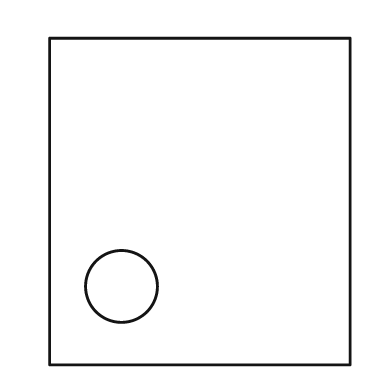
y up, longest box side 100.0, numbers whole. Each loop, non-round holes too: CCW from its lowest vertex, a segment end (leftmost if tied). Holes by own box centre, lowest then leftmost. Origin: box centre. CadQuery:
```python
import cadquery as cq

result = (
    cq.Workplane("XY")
    .moveTo(-46.0, -50.0)
    .lineTo(46.0, -50.0)
    .lineTo(46.0, 50.0)
    .lineTo(-46.0, 50.0)
    .close()
    .moveTo(-24.0, -26.0)
    .circle(11.0)
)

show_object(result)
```